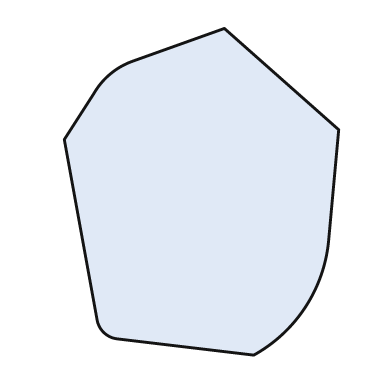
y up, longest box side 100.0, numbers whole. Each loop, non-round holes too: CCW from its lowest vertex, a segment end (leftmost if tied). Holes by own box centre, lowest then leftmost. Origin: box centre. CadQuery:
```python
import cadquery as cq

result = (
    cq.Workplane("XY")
    .moveTo(16.0, -50.0)
    .threePointArc((32.0, -35.0), (39.0, -14.0))
    .lineTo(42.0, 19.0)
    .lineTo(7.0, 50.0)
    .lineTo(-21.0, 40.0)
    .threePointArc((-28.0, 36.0), (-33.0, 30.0))
    .lineTo(-42.0, 16.0)
    .lineTo(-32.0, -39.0)
    .threePointArc((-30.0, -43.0), (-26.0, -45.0))
    .close()
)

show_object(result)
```